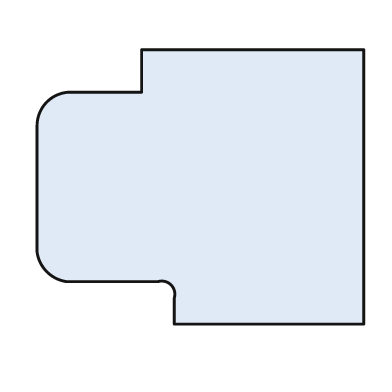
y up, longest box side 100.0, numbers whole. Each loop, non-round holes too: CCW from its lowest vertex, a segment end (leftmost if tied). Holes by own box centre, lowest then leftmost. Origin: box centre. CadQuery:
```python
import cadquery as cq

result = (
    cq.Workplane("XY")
    .moveTo(-8.0, -42.0)
    .lineTo(50.0, -42.0)
    .lineTo(50.0, 42.0)
    .lineTo(-18.0, 42.0)
    .lineTo(-18.0, 29.0)
    .lineTo(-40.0, 29.0)
    .threePointArc((-47.0, 26.0), (-50.0, 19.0))
    .lineTo(-50.0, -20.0)
    .threePointArc((-47.0, -26.0), (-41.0, -29.0))
    .lineTo(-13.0, -29.0)
    .threePointArc((-9.0, -30.0), (-8.0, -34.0))
    .close()
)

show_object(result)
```